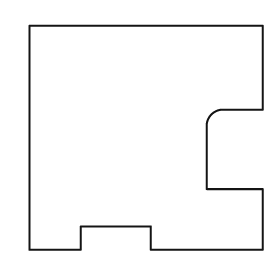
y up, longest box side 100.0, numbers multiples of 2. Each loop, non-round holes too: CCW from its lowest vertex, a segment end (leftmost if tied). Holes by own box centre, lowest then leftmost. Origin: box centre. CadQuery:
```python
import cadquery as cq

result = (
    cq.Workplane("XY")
    .moveTo(-50.0, -48.0)
    .lineTo(-28.0, -48.0)
    .lineTo(-28.0, -38.0)
    .lineTo(2.0, -38.0)
    .lineTo(2.0, -48.0)
    .lineTo(50.0, -48.0)
    .lineTo(50.0, -22.0)
    .lineTo(26.0, -22.0)
    .lineTo(26.0, 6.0)
    .threePointArc((28.0, 10.0), (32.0, 12.0))
    .lineTo(50.0, 12.0)
    .lineTo(50.0, 48.0)
    .lineTo(-50.0, 48.0)
    .close()
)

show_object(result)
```